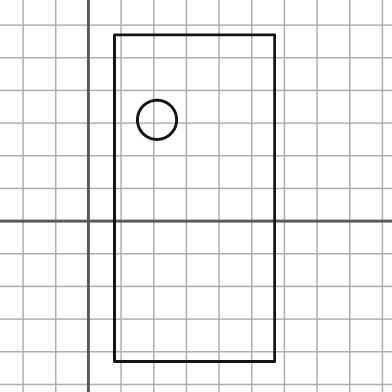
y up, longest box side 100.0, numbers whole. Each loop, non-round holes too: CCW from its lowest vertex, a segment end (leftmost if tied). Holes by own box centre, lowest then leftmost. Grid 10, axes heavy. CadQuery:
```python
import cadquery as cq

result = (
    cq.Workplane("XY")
    .moveTo(8.0, -43.0)
    .lineTo(57.0, -43.0)
    .lineTo(57.0, 57.0)
    .lineTo(8.0, 57.0)
    .close()
    .moveTo(21.0, 31.0)
    .circle(6.0)
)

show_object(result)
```